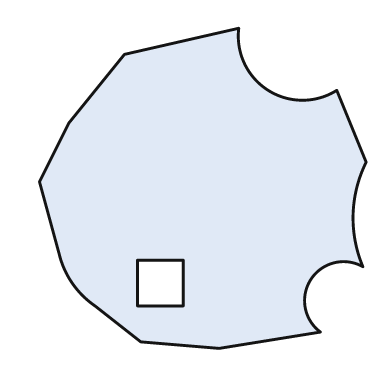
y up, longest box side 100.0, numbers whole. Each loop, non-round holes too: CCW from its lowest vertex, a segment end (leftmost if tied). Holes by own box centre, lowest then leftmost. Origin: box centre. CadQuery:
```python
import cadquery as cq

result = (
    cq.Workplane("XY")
    .moveTo(5.0, -49.0)
    .lineTo(36.0, -44.0)
    .threePointArc((33.0, -28.0), (49.0, -24.0))
    .threePointArc((46.0, -8.0), (50.0, 8.0))
    .lineTo(41.0, 30.0)
    .threePointArc((20.0, 30.0), (11.0, 49.0))
    .lineTo(-24.0, 41.0)
    .lineTo(-41.0, 20.0)
    .lineTo(-50.0, 2.0)
    .lineTo(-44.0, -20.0)
    .threePointArc((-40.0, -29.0), (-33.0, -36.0))
    .lineTo(-19.0, -47.0)
    .close()
    .moveTo(-20.0, -36.0)
    .lineTo(-6.0, -36.0)
    .lineTo(-6.0, -22.0)
    .lineTo(-20.0, -22.0)
    .close()
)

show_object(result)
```